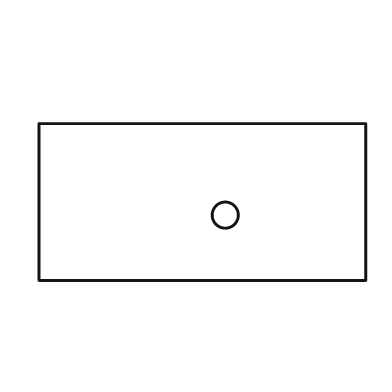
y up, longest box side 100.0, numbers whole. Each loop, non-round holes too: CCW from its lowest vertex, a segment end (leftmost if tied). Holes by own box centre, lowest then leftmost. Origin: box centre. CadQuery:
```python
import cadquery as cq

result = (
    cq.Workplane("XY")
    .moveTo(-50.0, -24.0)
    .lineTo(50.0, -24.0)
    .lineTo(50.0, 24.0)
    .lineTo(-50.0, 24.0)
    .close()
    .moveTo(7.0, -4.0)
    .circle(4.0)
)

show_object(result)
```